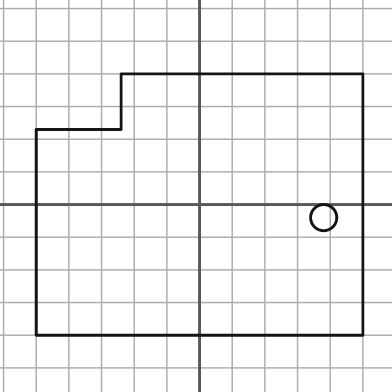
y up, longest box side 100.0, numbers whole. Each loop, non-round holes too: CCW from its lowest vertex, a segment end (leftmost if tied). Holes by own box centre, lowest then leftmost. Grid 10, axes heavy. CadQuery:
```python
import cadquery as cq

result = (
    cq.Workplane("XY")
    .moveTo(-50.0, -40.0)
    .lineTo(50.0, -40.0)
    .lineTo(50.0, 40.0)
    .lineTo(-24.0, 40.0)
    .lineTo(-24.0, 23.0)
    .lineTo(-50.0, 23.0)
    .close()
    .moveTo(38.0, -4.0)
    .circle(4.0)
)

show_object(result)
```